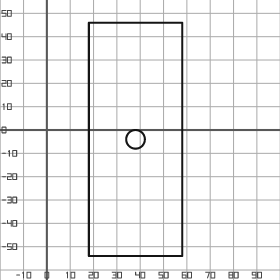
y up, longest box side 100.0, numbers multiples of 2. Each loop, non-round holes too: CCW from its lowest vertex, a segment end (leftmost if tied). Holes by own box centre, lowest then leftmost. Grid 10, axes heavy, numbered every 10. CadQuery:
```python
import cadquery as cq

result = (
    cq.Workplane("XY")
    .moveTo(18.0, -54.0)
    .lineTo(58.0, -54.0)
    .lineTo(58.0, 46.0)
    .lineTo(18.0, 46.0)
    .close()
    .moveTo(38.0, -4.0)
    .circle(4.0)
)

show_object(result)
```